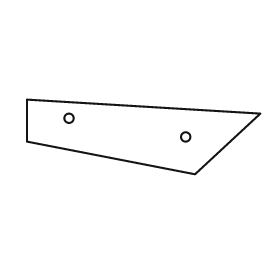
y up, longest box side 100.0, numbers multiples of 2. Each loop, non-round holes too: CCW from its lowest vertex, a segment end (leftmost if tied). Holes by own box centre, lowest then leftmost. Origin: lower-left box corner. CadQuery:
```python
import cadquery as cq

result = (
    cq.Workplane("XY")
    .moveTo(72.0, 0.0)
    .lineTo(100.0, 26.0)
    .lineTo(0.0, 32.0)
    .lineTo(0.0, 14.0)
    .close()
    .moveTo(68.0, 16.0)
    .circle(2.0)
    .moveTo(18.0, 24.0)
    .circle(2.0)
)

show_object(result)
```